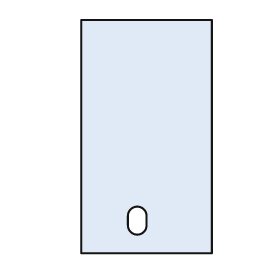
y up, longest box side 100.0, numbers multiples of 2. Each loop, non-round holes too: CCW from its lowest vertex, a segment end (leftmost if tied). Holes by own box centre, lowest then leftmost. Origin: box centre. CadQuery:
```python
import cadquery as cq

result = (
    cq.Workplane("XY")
    .moveTo(-28.0, -50.0)
    .lineTo(28.0, -50.0)
    .lineTo(28.0, 50.0)
    .lineTo(-28.0, 50.0)
    .close()
    .moveTo(-8.0, -38.0)
    .threePointArc((-4.0, -42.0), (0.0, -38.0))
    .lineTo(0.0, -34.0)
    .threePointArc((-4.0, -30.0), (-8.0, -34.0))
    .close()
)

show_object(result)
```